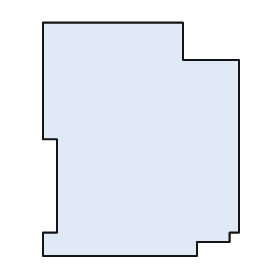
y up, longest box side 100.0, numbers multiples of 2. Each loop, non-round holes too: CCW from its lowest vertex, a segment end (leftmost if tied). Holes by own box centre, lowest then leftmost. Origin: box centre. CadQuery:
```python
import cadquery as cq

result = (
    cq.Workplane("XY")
    .moveTo(-42.0, -50.0)
    .lineTo(24.0, -50.0)
    .lineTo(24.0, -44.0)
    .lineTo(38.0, -44.0)
    .lineTo(38.0, -40.0)
    .lineTo(42.0, -40.0)
    .lineTo(42.0, 34.0)
    .lineTo(18.0, 34.0)
    .lineTo(18.0, 50.0)
    .lineTo(-42.0, 50.0)
    .lineTo(-42.0, 0.0)
    .lineTo(-36.0, 0.0)
    .lineTo(-36.0, -40.0)
    .lineTo(-42.0, -40.0)
    .close()
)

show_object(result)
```